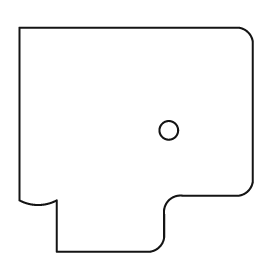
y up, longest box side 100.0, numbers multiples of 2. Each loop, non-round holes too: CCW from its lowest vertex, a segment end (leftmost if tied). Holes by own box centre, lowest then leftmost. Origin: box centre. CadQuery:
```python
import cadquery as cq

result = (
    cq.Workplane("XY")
    .moveTo(-34.0, -48.0)
    .lineTo(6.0, -48.0)
    .threePointArc((10.0, -46.0), (12.0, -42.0))
    .lineTo(12.0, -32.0)
    .threePointArc((14.0, -26.0), (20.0, -24.0))
    .lineTo(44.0, -24.0)
    .threePointArc((48.0, -22.0), (50.0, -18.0))
    .lineTo(50.0, 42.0)
    .threePointArc((48.0, 46.0), (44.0, 48.0))
    .lineTo(-50.0, 48.0)
    .lineTo(-50.0, -26.0)
    .threePointArc((-42.0, -28.0), (-34.0, -26.0))
    .close()
    .moveTo(14.0, 4.0)
    .circle(4.0)
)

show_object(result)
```